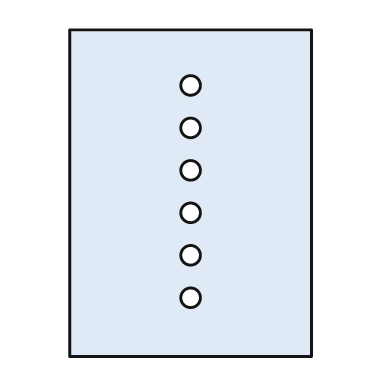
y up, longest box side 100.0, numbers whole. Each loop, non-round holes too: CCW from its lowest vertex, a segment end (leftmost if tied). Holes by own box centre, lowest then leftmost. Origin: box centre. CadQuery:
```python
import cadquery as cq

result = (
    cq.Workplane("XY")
    .moveTo(-37.0, -50.0)
    .lineTo(37.0, -50.0)
    .lineTo(37.0, 50.0)
    .lineTo(-37.0, 50.0)
    .close()
    .moveTo(0.0, -32.0)
    .circle(3.0)
    .moveTo(0.0, -19.0)
    .circle(3.0)
    .moveTo(0.0, -6.0)
    .circle(3.0)
    .moveTo(0.0, 7.0)
    .circle(3.0)
    .moveTo(0.0, 20.0)
    .circle(3.0)
    .moveTo(0.0, 33.0)
    .circle(3.0)
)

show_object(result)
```